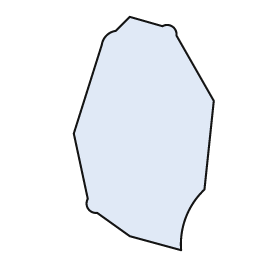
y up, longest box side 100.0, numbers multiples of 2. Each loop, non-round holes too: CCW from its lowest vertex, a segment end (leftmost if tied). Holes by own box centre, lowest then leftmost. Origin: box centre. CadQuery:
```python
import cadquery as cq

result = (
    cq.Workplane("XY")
    .moveTo(16.0, -50.0)
    .threePointArc((18.0, -36.0), (26.0, -24.0))
    .lineTo(30.0, 14.0)
    .lineTo(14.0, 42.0)
    .threePointArc((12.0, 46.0), (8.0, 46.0))
    .lineTo(-6.0, 50.0)
    .lineTo(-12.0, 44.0)
    .threePointArc((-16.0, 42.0), (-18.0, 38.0))
    .lineTo(-30.0, 0.0)
    .lineTo(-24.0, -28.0)
    .threePointArc((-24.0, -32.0), (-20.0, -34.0))
    .lineTo(-6.0, -44.0)
    .close()
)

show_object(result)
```